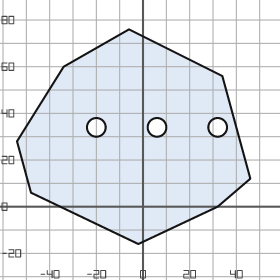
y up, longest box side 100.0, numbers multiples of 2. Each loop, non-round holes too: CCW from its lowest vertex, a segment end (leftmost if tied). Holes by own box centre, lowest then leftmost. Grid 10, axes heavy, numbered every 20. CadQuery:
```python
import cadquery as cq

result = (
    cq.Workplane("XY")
    .moveTo(-2.0, -16.0)
    .lineTo(32.0, 0.0)
    .lineTo(46.0, 12.0)
    .lineTo(34.0, 56.0)
    .lineTo(-6.0, 76.0)
    .lineTo(-34.0, 60.0)
    .lineTo(-54.0, 28.0)
    .lineTo(-48.0, 6.0)
    .close()
    .moveTo(-20.0, 34.0)
    .circle(4.0)
    .moveTo(6.0, 34.0)
    .circle(4.0)
    .moveTo(32.0, 34.0)
    .circle(4.0)
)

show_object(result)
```